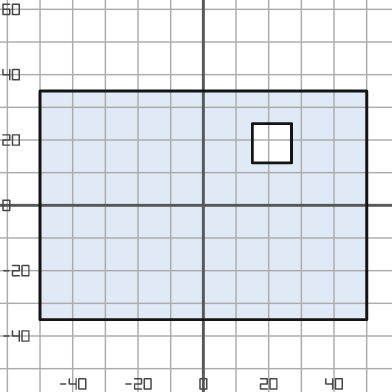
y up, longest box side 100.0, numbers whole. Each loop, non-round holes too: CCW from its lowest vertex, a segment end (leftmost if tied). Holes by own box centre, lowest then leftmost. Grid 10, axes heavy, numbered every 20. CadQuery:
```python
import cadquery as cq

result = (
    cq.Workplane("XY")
    .moveTo(-50.0, -35.0)
    .lineTo(50.0, -35.0)
    .lineTo(50.0, 35.0)
    .lineTo(-50.0, 35.0)
    .close()
    .moveTo(15.0, 13.0)
    .lineTo(27.0, 13.0)
    .lineTo(27.0, 25.0)
    .lineTo(15.0, 25.0)
    .close()
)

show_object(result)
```